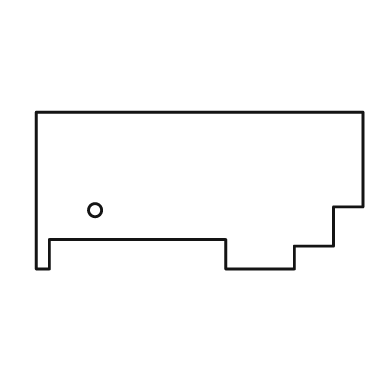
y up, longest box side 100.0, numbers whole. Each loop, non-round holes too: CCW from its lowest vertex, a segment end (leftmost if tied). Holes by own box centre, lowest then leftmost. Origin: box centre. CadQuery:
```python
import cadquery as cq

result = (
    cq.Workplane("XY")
    .moveTo(-50.0, -24.0)
    .lineTo(-46.0, -24.0)
    .lineTo(-46.0, -15.0)
    .lineTo(8.0, -15.0)
    .lineTo(8.0, -24.0)
    .lineTo(29.0, -24.0)
    .lineTo(29.0, -17.0)
    .lineTo(41.0, -17.0)
    .lineTo(41.0, -5.0)
    .lineTo(50.0, -5.0)
    .lineTo(50.0, 24.0)
    .lineTo(-50.0, 24.0)
    .close()
    .moveTo(-32.0, -6.0)
    .circle(2.0)
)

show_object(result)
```